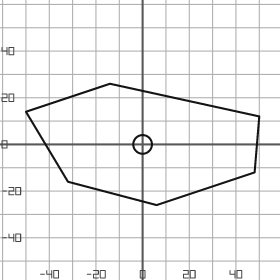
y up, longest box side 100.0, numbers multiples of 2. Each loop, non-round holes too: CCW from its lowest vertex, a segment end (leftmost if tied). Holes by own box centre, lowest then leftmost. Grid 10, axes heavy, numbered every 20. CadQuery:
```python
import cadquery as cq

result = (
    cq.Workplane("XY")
    .moveTo(6.0, -26.0)
    .lineTo(48.0, -12.0)
    .lineTo(50.0, 12.0)
    .lineTo(-14.0, 26.0)
    .lineTo(-50.0, 14.0)
    .lineTo(-32.0, -16.0)
    .close()
    .moveTo(0.0, 0.0)
    .circle(4.0)
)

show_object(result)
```